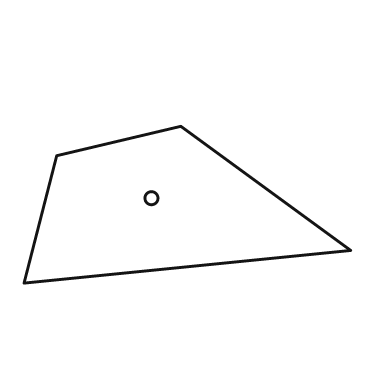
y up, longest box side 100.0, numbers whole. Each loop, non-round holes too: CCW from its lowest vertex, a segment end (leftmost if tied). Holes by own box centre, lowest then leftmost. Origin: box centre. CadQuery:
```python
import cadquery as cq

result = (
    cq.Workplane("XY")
    .moveTo(-50.0, -24.0)
    .lineTo(50.0, -14.0)
    .lineTo(-2.0, 24.0)
    .lineTo(-40.0, 15.0)
    .close()
    .moveTo(-11.0, 2.0)
    .circle(2.0)
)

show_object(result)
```